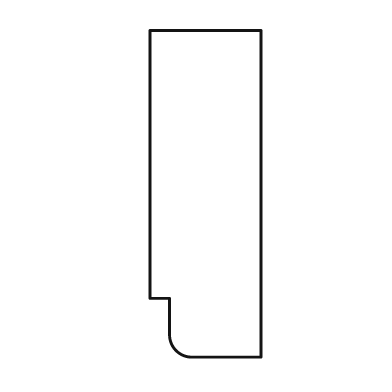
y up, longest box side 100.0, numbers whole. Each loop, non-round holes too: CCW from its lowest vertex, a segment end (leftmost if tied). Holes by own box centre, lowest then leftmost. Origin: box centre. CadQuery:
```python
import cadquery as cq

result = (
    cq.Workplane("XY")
    .moveTo(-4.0, -50.0)
    .lineTo(17.0, -50.0)
    .lineTo(17.0, 50.0)
    .lineTo(-17.0, 50.0)
    .lineTo(-17.0, -32.0)
    .lineTo(-11.0, -32.0)
    .lineTo(-11.0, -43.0)
    .threePointArc((-9.0, -48.0), (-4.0, -50.0))
    .close()
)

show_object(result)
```